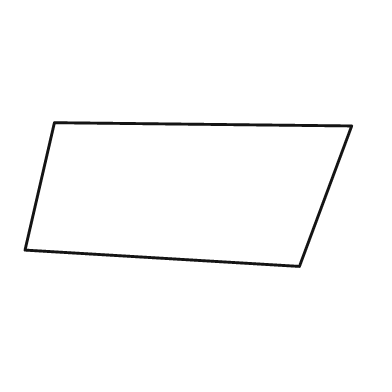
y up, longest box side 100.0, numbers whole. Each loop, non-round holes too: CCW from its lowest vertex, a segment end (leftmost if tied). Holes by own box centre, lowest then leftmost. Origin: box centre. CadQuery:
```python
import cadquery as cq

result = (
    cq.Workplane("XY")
    .moveTo(34.0, -22.0)
    .lineTo(50.0, 21.0)
    .lineTo(-41.0, 22.0)
    .lineTo(-50.0, -17.0)
    .close()
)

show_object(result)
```